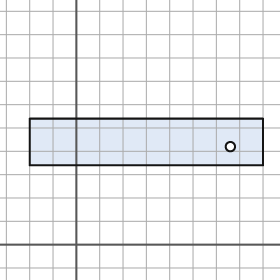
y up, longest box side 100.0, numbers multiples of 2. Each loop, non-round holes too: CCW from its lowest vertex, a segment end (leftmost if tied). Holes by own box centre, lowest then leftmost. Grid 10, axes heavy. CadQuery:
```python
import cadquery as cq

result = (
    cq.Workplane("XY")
    .moveTo(-20.0, 34.0)
    .lineTo(80.0, 34.0)
    .lineTo(80.0, 54.0)
    .lineTo(-20.0, 54.0)
    .close()
    .moveTo(66.0, 42.0)
    .circle(2.0)
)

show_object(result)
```